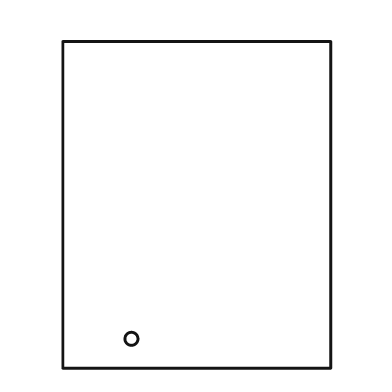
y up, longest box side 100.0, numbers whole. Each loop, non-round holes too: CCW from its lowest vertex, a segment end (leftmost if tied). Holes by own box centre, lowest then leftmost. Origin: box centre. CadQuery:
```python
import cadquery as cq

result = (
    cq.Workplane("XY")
    .moveTo(-41.0, -50.0)
    .lineTo(41.0, -50.0)
    .lineTo(41.0, 50.0)
    .lineTo(-41.0, 50.0)
    .close()
    .moveTo(-20.0, -41.0)
    .circle(2.0)
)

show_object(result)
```